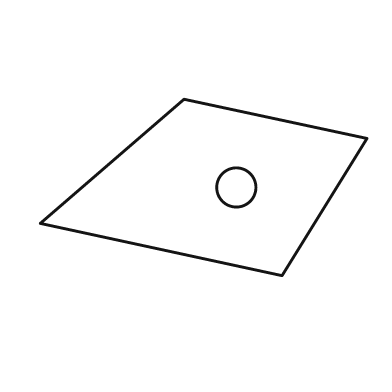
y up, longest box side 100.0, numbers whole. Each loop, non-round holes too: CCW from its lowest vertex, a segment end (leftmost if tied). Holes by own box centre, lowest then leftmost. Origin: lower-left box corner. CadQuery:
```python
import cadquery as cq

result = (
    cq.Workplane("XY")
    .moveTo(74.0, 0.0)
    .lineTo(100.0, 42.0)
    .lineTo(44.0, 54.0)
    .lineTo(0.0, 16.0)
    .close()
    .moveTo(60.0, 27.0)
    .circle(6.0)
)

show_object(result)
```